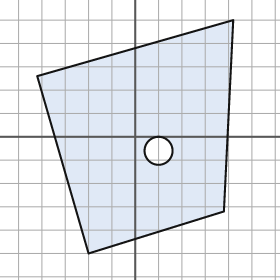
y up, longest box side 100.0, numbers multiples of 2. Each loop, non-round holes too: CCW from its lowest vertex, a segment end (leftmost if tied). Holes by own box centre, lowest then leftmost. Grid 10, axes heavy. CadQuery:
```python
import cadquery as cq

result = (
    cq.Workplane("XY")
    .moveTo(-20.0, -50.0)
    .lineTo(38.0, -32.0)
    .lineTo(42.0, 50.0)
    .lineTo(-42.0, 26.0)
    .close()
    .moveTo(10.0, -6.0)
    .circle(6.0)
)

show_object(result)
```